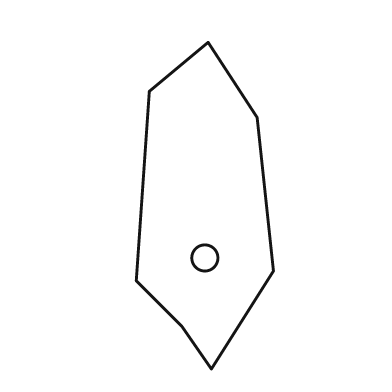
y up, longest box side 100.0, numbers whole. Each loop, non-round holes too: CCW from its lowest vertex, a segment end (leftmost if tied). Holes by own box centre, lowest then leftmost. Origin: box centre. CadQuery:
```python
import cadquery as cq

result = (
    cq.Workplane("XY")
    .moveTo(2.0, -50.0)
    .lineTo(21.0, -20.0)
    .lineTo(16.0, 27.0)
    .lineTo(1.0, 50.0)
    .lineTo(-17.0, 35.0)
    .lineTo(-21.0, -23.0)
    .lineTo(-7.0, -37.0)
    .close()
    .moveTo(0.0, -16.0)
    .circle(4.0)
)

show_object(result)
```